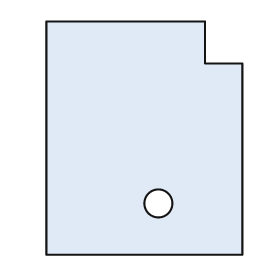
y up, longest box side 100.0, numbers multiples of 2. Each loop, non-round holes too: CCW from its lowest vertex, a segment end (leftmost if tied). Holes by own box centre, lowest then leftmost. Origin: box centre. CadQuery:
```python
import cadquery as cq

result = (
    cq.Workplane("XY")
    .moveTo(-42.0, -50.0)
    .lineTo(42.0, -50.0)
    .lineTo(42.0, 32.0)
    .lineTo(26.0, 32.0)
    .lineTo(26.0, 50.0)
    .lineTo(-42.0, 50.0)
    .close()
    .moveTo(6.0, -28.0)
    .circle(6.0)
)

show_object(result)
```